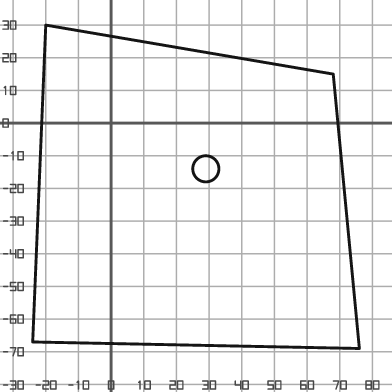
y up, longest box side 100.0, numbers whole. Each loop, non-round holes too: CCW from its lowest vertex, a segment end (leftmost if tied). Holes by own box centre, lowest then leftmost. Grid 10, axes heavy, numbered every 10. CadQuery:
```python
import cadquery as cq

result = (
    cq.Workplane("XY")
    .moveTo(76.0, -69.0)
    .lineTo(68.0, 15.0)
    .lineTo(-20.0, 30.0)
    .lineTo(-24.0, -67.0)
    .close()
    .moveTo(29.0, -14.0)
    .circle(4.0)
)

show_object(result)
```